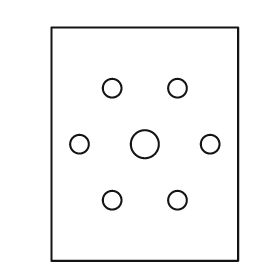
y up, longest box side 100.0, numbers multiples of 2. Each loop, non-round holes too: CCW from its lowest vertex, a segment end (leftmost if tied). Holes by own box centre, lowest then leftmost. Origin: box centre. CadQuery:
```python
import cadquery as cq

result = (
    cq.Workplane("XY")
    .moveTo(-40.0, -50.0)
    .lineTo(40.0, -50.0)
    .lineTo(40.0, 50.0)
    .lineTo(-40.0, 50.0)
    .close()
    .moveTo(-14.0, -24.0)
    .circle(4.0)
    .moveTo(14.0, -24.0)
    .circle(4.0)
    .moveTo(-28.0, 0.0)
    .circle(4.0)
    .moveTo(0.0, 0.0)
    .circle(6.0)
    .moveTo(28.0, 0.0)
    .circle(4.0)
    .moveTo(-14.0, 24.0)
    .circle(4.0)
    .moveTo(14.0, 24.0)
    .circle(4.0)
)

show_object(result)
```